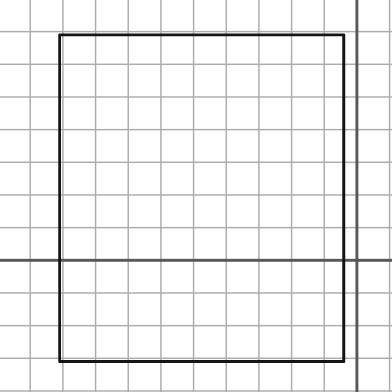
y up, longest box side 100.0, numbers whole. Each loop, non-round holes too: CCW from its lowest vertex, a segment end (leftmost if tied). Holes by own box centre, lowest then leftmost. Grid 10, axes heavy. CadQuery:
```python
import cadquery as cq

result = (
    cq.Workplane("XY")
    .moveTo(-91.0, -31.0)
    .lineTo(-4.0, -31.0)
    .lineTo(-4.0, 69.0)
    .lineTo(-91.0, 69.0)
    .close()
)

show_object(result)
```